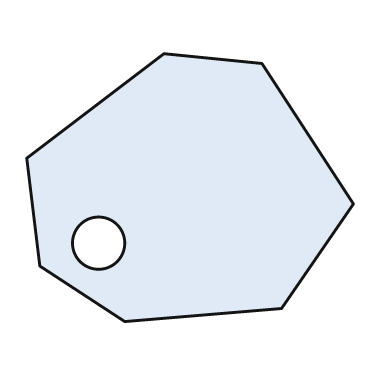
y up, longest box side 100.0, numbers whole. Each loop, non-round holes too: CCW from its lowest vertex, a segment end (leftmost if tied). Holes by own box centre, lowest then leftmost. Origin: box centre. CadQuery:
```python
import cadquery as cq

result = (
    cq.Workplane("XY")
    .moveTo(-20.0, -41.0)
    .lineTo(28.0, -37.0)
    .lineTo(50.0, -5.0)
    .lineTo(22.0, 38.0)
    .lineTo(-8.0, 41.0)
    .lineTo(-50.0, 9.0)
    .lineTo(-46.0, -24.0)
    .close()
    .moveTo(-28.0, -17.0)
    .circle(8.0)
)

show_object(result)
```